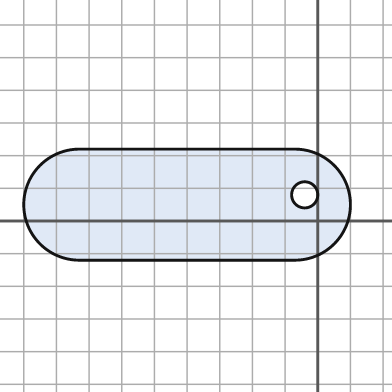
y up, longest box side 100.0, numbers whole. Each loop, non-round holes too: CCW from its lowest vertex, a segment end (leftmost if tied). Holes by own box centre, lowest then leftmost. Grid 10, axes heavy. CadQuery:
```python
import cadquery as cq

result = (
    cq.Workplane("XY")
    .moveTo(-73.0, -12.0)
    .lineTo(-7.0, -12.0)
    .threePointArc((10.0, 5.0), (-7.0, 22.0))
    .lineTo(-73.0, 22.0)
    .threePointArc((-90.0, 5.0), (-73.0, -12.0))
    .close()
    .moveTo(-4.0, 8.0)
    .circle(4.0)
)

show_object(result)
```